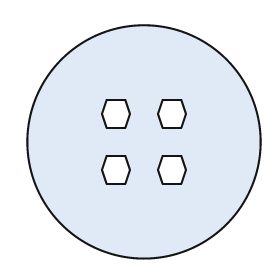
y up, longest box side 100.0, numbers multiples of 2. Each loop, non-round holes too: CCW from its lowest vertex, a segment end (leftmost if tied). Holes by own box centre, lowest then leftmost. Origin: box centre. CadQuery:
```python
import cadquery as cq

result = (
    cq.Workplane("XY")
    .moveTo(0.0, 0.0)
    .circle(50.0)
    .moveTo(-16.0, -18.0)
    .lineTo(-8.0, -18.0)
    .lineTo(-6.0, -12.0)
    .lineTo(-8.0, -6.0)
    .lineTo(-16.0, -6.0)
    .lineTo(-18.0, -12.0)
    .close()
    .moveTo(8.0, -18.0)
    .lineTo(16.0, -18.0)
    .lineTo(18.0, -12.0)
    .lineTo(16.0, -6.0)
    .lineTo(8.0, -6.0)
    .lineTo(6.0, -12.0)
    .close()
    .moveTo(-16.0, 6.0)
    .lineTo(-8.0, 6.0)
    .lineTo(-6.0, 12.0)
    .lineTo(-8.0, 18.0)
    .lineTo(-16.0, 18.0)
    .lineTo(-18.0, 12.0)
    .close()
    .moveTo(8.0, 6.0)
    .lineTo(16.0, 6.0)
    .lineTo(18.0, 12.0)
    .lineTo(16.0, 18.0)
    .lineTo(8.0, 18.0)
    .lineTo(6.0, 12.0)
    .close()
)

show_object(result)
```